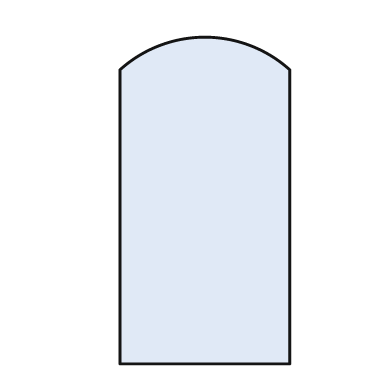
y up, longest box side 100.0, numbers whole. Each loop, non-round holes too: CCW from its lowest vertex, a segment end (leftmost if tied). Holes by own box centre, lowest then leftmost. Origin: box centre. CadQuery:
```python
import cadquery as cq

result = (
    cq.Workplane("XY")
    .moveTo(-26.0, -50.0)
    .lineTo(26.0, -50.0)
    .lineTo(26.0, 40.0)
    .threePointArc((0.0, 50.0), (-26.0, 40.0))
    .close()
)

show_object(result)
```